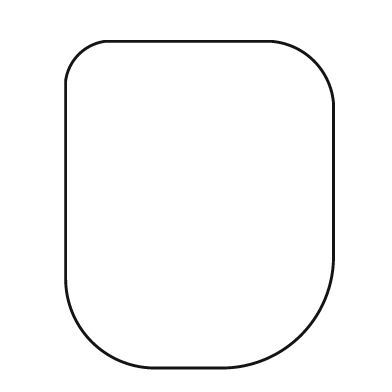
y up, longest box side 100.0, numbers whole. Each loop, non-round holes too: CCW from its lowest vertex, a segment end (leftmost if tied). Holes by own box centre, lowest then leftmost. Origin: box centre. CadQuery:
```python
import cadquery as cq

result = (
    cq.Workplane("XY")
    .moveTo(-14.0, -50.0)
    .lineTo(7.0, -50.0)
    .threePointArc((31.0, -40.0), (41.0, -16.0))
    .lineTo(41.0, 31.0)
    .threePointArc((35.0, 44.0), (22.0, 50.0))
    .lineTo(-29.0, 50.0)
    .threePointArc((-37.0, 46.0), (-41.0, 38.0))
    .lineTo(-41.0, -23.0)
    .threePointArc((-33.0, -42.0), (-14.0, -50.0))
    .close()
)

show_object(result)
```